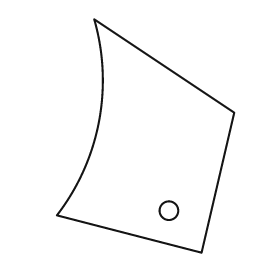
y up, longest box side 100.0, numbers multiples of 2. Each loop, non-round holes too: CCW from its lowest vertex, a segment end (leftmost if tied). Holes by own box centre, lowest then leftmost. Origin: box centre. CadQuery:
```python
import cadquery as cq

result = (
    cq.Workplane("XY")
    .moveTo(24.0, -50.0)
    .lineTo(38.0, 10.0)
    .lineTo(-22.0, 50.0)
    .threePointArc((-20.0, 6.0), (-38.0, -34.0))
    .close()
    .moveTo(10.0, -32.0)
    .circle(4.0)
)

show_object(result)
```